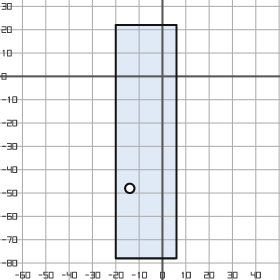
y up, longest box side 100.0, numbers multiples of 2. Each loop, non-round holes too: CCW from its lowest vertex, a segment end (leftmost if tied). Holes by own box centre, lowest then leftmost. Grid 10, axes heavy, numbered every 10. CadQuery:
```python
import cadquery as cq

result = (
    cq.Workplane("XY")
    .moveTo(-20.0, -78.0)
    .lineTo(6.0, -78.0)
    .lineTo(6.0, 22.0)
    .lineTo(-20.0, 22.0)
    .close()
    .moveTo(-14.0, -48.0)
    .circle(2.0)
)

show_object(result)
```